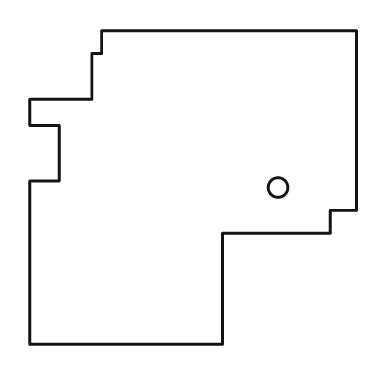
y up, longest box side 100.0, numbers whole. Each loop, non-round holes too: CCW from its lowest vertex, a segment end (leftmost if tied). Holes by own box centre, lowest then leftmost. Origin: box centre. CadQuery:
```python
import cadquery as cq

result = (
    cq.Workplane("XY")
    .moveTo(-50.0, -48.0)
    .lineTo(9.0, -48.0)
    .lineTo(9.0, -14.0)
    .lineTo(42.0, -14.0)
    .lineTo(42.0, -7.0)
    .lineTo(50.0, -7.0)
    .lineTo(50.0, 48.0)
    .lineTo(-28.0, 48.0)
    .lineTo(-28.0, 41.0)
    .lineTo(-31.0, 41.0)
    .lineTo(-31.0, 27.0)
    .lineTo(-50.0, 27.0)
    .lineTo(-50.0, 19.0)
    .lineTo(-41.0, 19.0)
    .lineTo(-41.0, 2.0)
    .lineTo(-50.0, 2.0)
    .close()
    .moveTo(26.0, 0.0)
    .circle(3.0)
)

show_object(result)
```